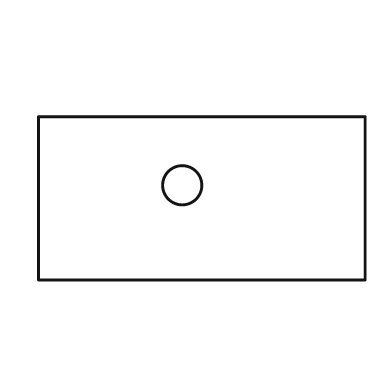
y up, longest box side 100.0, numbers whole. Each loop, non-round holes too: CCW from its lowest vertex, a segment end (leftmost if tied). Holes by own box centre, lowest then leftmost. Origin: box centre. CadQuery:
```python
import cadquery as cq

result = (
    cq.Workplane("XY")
    .moveTo(-50.0, -25.0)
    .lineTo(50.0, -25.0)
    .lineTo(50.0, 25.0)
    .lineTo(-50.0, 25.0)
    .close()
    .moveTo(-6.0, 4.0)
    .circle(6.0)
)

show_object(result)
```